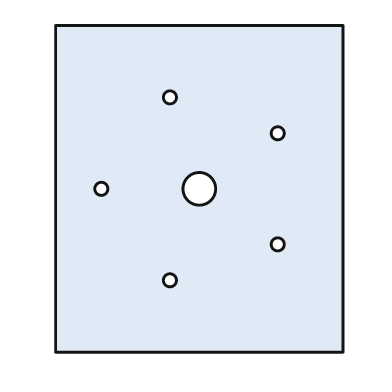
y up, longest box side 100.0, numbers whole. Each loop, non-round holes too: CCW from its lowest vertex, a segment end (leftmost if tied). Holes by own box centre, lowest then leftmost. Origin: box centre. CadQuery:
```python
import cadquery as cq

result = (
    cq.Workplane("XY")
    .moveTo(-44.0, -50.0)
    .lineTo(44.0, -50.0)
    .lineTo(44.0, 50.0)
    .lineTo(-44.0, 50.0)
    .close()
    .moveTo(-9.0, -28.0)
    .circle(2.0)
    .moveTo(24.0, -17.0)
    .circle(2.0)
    .moveTo(-30.0, 0.0)
    .circle(2.0)
    .moveTo(0.0, 0.0)
    .circle(5.0)
    .moveTo(24.0, 17.0)
    .circle(2.0)
    .moveTo(-9.0, 28.0)
    .circle(2.0)
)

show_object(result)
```